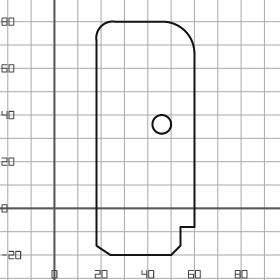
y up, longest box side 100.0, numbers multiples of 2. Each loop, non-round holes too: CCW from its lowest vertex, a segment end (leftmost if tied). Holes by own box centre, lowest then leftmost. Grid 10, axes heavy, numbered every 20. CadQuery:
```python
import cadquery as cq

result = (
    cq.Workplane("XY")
    .moveTo(24.0, -20.0)
    .lineTo(50.0, -20.0)
    .lineTo(54.0, -16.0)
    .lineTo(54.0, -8.0)
    .lineTo(60.0, -8.0)
    .lineTo(60.0, 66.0)
    .threePointArc((56.0, 76.0), (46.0, 80.0))
    .lineTo(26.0, 80.0)
    .threePointArc((20.0, 78.0), (18.0, 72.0))
    .lineTo(18.0, -16.0)
    .close()
    .moveTo(46.0, 36.0)
    .circle(4.0)
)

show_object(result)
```